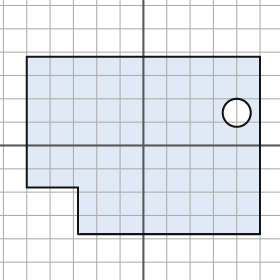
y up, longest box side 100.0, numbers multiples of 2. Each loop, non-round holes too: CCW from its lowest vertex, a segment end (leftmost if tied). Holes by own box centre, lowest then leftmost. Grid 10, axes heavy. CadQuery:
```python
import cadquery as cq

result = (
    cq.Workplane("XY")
    .moveTo(-28.0, -38.0)
    .lineTo(50.0, -38.0)
    .lineTo(50.0, 38.0)
    .lineTo(-50.0, 38.0)
    .lineTo(-50.0, -18.0)
    .lineTo(-28.0, -18.0)
    .close()
    .moveTo(40.0, 14.0)
    .circle(6.0)
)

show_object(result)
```